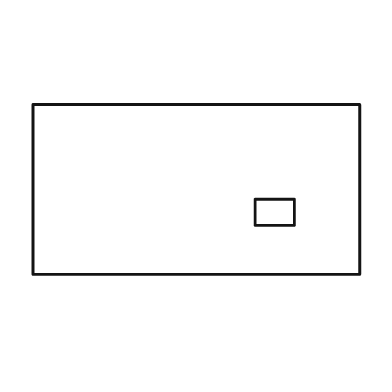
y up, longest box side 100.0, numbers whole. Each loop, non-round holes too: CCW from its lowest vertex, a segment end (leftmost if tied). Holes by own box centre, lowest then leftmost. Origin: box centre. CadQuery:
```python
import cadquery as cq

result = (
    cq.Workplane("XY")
    .moveTo(-50.0, -26.0)
    .lineTo(50.0, -26.0)
    .lineTo(50.0, 26.0)
    .lineTo(-50.0, 26.0)
    .close()
    .moveTo(18.0, -11.0)
    .lineTo(30.0, -11.0)
    .lineTo(30.0, -3.0)
    .lineTo(18.0, -3.0)
    .close()
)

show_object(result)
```